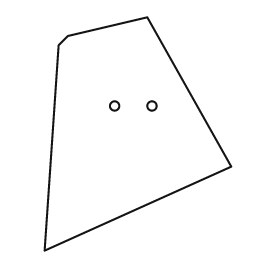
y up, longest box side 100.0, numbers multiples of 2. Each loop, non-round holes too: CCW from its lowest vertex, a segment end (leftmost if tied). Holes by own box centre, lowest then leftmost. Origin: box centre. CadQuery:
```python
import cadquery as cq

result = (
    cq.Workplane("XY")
    .moveTo(-40.0, -50.0)
    .lineTo(40.0, -14.0)
    .lineTo(4.0, 50.0)
    .lineTo(-30.0, 42.0)
    .lineTo(-34.0, 38.0)
    .close()
    .moveTo(-10.0, 12.0)
    .circle(2.0)
    .moveTo(6.0, 12.0)
    .circle(2.0)
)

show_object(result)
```